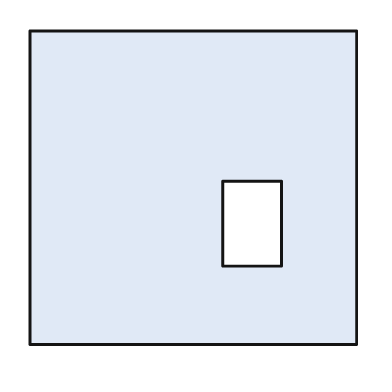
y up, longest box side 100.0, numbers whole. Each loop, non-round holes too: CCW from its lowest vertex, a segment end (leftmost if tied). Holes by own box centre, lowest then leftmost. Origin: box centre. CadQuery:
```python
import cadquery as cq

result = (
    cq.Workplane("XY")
    .moveTo(-50.0, -48.0)
    .lineTo(50.0, -48.0)
    .lineTo(50.0, 48.0)
    .lineTo(-50.0, 48.0)
    .close()
    .moveTo(9.0, -24.0)
    .lineTo(27.0, -24.0)
    .lineTo(27.0, 2.0)
    .lineTo(9.0, 2.0)
    .close()
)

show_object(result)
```